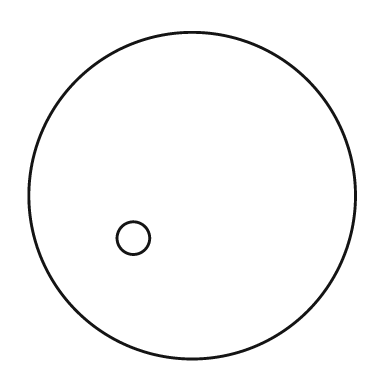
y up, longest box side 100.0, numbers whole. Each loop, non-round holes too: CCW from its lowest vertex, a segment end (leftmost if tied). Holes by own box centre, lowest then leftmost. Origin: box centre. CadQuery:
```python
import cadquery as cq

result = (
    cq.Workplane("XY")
    .moveTo(0.0, 0.0)
    .circle(50.0)
    .moveTo(-18.0, -13.0)
    .circle(5.0)
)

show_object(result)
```